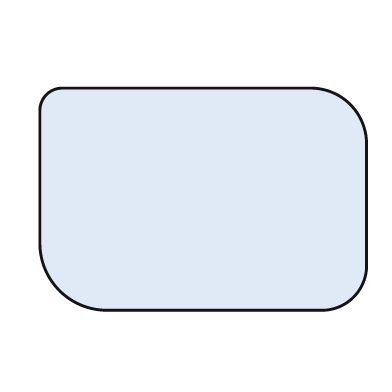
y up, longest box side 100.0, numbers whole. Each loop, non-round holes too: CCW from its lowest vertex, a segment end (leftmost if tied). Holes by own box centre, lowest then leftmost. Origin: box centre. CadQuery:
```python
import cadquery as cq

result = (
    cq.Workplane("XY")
    .moveTo(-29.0, -34.0)
    .lineTo(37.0, -34.0)
    .threePointArc((46.0, -30.0), (50.0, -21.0))
    .lineTo(50.0, 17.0)
    .threePointArc((45.0, 29.0), (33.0, 34.0))
    .lineTo(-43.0, 34.0)
    .threePointArc((-48.0, 32.0), (-50.0, 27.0))
    .lineTo(-50.0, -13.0)
    .threePointArc((-44.0, -28.0), (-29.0, -34.0))
    .close()
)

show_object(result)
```